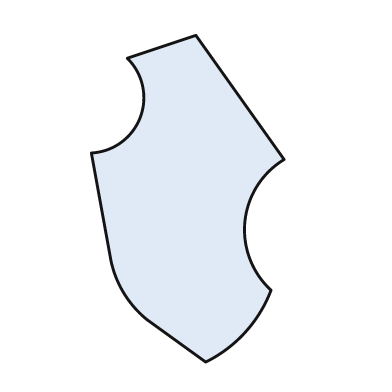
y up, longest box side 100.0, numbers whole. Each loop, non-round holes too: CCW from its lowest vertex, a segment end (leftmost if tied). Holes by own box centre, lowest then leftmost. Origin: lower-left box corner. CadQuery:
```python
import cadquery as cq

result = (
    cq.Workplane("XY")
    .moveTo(35.0, 0.0)
    .threePointArc((47.0, 9.0), (55.0, 22.0))
    .threePointArc((47.0, 43.0), (59.0, 62.0))
    .lineTo(32.0, 100.0)
    .lineTo(11.0, 93.0)
    .threePointArc((15.0, 75.0), (0.0, 64.0))
    .lineTo(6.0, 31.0)
    .threePointArc((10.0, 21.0), (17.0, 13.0))
    .close()
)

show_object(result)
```